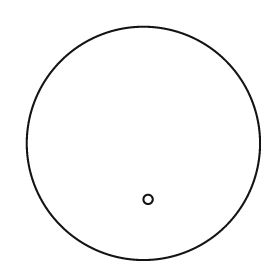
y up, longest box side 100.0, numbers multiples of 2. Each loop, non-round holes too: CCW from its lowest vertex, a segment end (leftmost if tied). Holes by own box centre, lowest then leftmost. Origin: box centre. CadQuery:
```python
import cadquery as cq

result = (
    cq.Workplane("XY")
    .moveTo(0.0, 0.0)
    .circle(50.0)
    .moveTo(2.0, -24.0)
    .circle(2.0)
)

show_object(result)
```